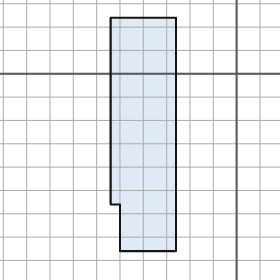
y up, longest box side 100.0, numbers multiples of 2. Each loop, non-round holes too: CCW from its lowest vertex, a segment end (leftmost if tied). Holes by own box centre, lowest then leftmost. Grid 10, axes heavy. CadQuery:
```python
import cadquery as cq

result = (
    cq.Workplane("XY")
    .moveTo(-50.0, -76.0)
    .lineTo(-26.0, -76.0)
    .lineTo(-26.0, 24.0)
    .lineTo(-54.0, 24.0)
    .lineTo(-54.0, -56.0)
    .lineTo(-50.0, -56.0)
    .close()
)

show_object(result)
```